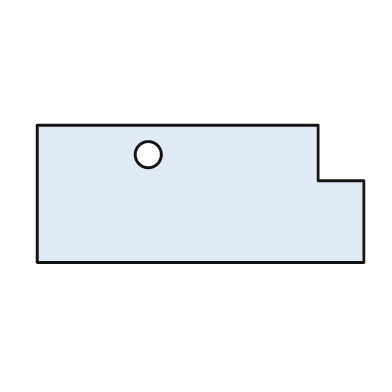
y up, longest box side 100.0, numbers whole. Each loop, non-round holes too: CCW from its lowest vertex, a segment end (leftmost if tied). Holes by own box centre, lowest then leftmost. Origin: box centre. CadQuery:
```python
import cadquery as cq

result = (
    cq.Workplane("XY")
    .moveTo(-50.0, -21.0)
    .lineTo(50.0, -21.0)
    .lineTo(50.0, 4.0)
    .lineTo(36.0, 4.0)
    .lineTo(36.0, 21.0)
    .lineTo(-50.0, 21.0)
    .close()
    .moveTo(-16.0, 12.0)
    .circle(4.0)
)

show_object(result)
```